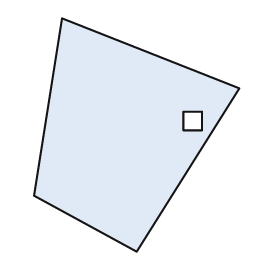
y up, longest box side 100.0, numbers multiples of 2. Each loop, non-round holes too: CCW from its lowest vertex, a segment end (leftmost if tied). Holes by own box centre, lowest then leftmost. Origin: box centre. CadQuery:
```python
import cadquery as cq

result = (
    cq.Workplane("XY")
    .moveTo(0.0, -50.0)
    .lineTo(44.0, 20.0)
    .lineTo(-32.0, 50.0)
    .lineTo(-44.0, -26.0)
    .close()
    .moveTo(20.0, 2.0)
    .lineTo(28.0, 2.0)
    .lineTo(28.0, 10.0)
    .lineTo(20.0, 10.0)
    .close()
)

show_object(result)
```